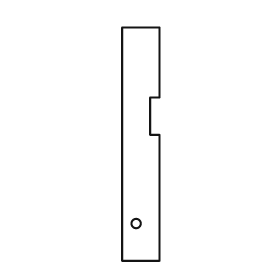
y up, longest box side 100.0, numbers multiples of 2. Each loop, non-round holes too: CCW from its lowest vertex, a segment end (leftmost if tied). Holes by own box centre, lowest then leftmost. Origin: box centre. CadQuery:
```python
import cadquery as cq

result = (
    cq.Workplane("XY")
    .moveTo(-8.0, -50.0)
    .lineTo(8.0, -50.0)
    .lineTo(8.0, 4.0)
    .lineTo(4.0, 4.0)
    .lineTo(4.0, 20.0)
    .lineTo(8.0, 20.0)
    .lineTo(8.0, 50.0)
    .lineTo(-8.0, 50.0)
    .close()
    .moveTo(-2.0, -34.0)
    .circle(2.0)
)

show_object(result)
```